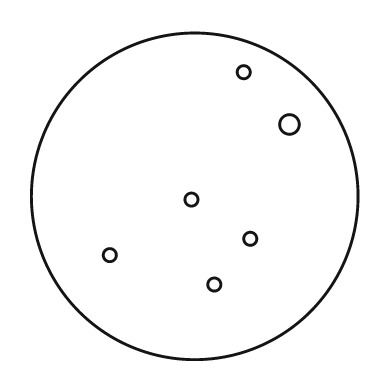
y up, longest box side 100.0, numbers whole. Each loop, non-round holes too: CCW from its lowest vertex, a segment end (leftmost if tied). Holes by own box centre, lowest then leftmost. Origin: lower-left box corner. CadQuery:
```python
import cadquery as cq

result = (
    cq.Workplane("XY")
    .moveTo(50.0, 50.0)
    .circle(50.0)
    .moveTo(56.0, 23.0)
    .circle(2.0)
    .moveTo(24.0, 32.0)
    .circle(2.0)
    .moveTo(67.0, 37.0)
    .circle(2.0)
    .moveTo(49.0, 49.0)
    .circle(2.0)
    .moveTo(79.0, 72.0)
    .circle(3.0)
    .moveTo(65.0, 88.0)
    .circle(2.0)
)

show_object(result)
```